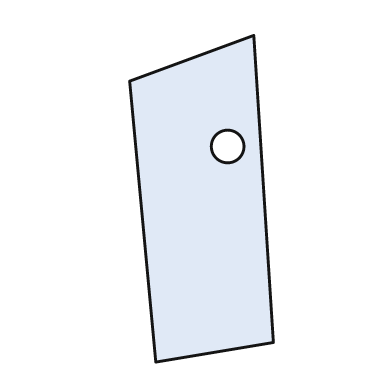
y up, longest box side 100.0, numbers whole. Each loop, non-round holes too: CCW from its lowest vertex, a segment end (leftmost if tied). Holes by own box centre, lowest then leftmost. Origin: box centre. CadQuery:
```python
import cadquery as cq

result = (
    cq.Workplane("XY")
    .moveTo(-14.0, -50.0)
    .lineTo(22.0, -44.0)
    .lineTo(16.0, 50.0)
    .lineTo(-22.0, 36.0)
    .close()
    .moveTo(8.0, 16.0)
    .circle(5.0)
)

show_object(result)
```